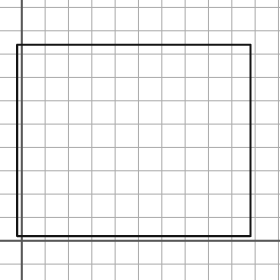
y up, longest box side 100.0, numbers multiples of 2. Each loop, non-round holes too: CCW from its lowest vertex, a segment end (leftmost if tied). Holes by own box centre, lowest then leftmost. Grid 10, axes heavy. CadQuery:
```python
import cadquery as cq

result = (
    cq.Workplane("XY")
    .moveTo(-2.0, 2.0)
    .lineTo(98.0, 2.0)
    .lineTo(98.0, 84.0)
    .lineTo(-2.0, 84.0)
    .close()
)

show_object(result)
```